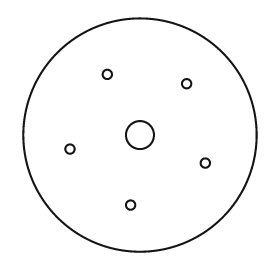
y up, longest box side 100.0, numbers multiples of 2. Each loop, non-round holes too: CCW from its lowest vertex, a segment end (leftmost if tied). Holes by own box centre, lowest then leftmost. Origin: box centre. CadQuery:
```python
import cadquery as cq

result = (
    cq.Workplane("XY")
    .moveTo(0.0, 0.0)
    .circle(50.0)
    .moveTo(-4.0, -30.0)
    .circle(2.0)
    .moveTo(28.0, -12.0)
    .circle(2.0)
    .moveTo(-30.0, -6.0)
    .circle(2.0)
    .moveTo(0.0, 0.0)
    .circle(6.0)
    .moveTo(20.0, 22.0)
    .circle(2.0)
    .moveTo(-14.0, 26.0)
    .circle(2.0)
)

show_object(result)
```